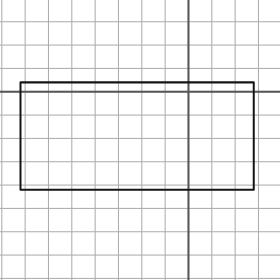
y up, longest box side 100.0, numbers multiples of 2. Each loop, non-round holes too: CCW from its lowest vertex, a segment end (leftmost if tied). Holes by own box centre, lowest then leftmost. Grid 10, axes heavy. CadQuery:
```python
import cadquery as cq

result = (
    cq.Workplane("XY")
    .moveTo(-72.0, -42.0)
    .lineTo(28.0, -42.0)
    .lineTo(28.0, 4.0)
    .lineTo(-72.0, 4.0)
    .close()
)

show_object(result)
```